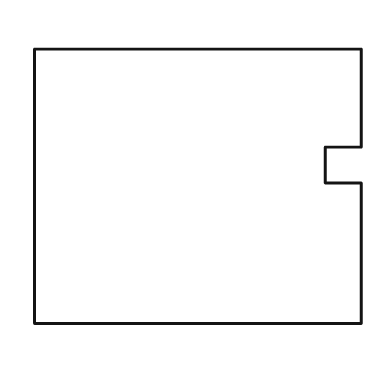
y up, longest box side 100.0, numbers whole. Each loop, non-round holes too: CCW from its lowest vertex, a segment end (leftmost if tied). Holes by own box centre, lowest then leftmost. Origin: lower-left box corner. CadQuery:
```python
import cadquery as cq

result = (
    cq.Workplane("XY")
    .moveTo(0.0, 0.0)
    .lineTo(100.0, 0.0)
    .lineTo(100.0, 43.0)
    .lineTo(89.0, 43.0)
    .lineTo(89.0, 54.0)
    .lineTo(100.0, 54.0)
    .lineTo(100.0, 84.0)
    .lineTo(0.0, 84.0)
    .close()
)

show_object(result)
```